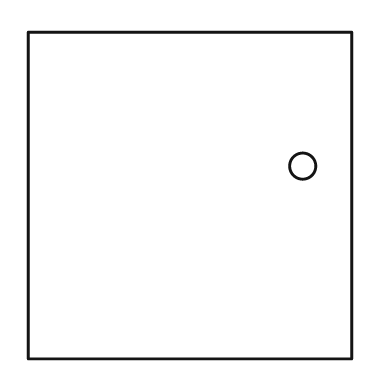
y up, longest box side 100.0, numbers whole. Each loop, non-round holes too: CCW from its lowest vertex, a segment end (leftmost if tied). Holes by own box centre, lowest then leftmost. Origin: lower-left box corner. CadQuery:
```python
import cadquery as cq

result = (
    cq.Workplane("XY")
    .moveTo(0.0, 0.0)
    .lineTo(99.0, 0.0)
    .lineTo(99.0, 100.0)
    .lineTo(0.0, 100.0)
    .close()
    .moveTo(84.0, 59.0)
    .circle(4.0)
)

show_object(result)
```